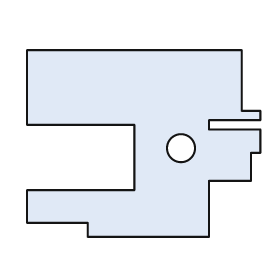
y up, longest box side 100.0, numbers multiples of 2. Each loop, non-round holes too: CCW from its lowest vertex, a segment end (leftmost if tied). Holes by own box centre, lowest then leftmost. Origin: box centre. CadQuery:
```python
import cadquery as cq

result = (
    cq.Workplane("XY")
    .moveTo(-24.0, -40.0)
    .lineTo(28.0, -40.0)
    .lineTo(28.0, -16.0)
    .lineTo(46.0, -16.0)
    .lineTo(46.0, -4.0)
    .lineTo(50.0, -4.0)
    .lineTo(50.0, 6.0)
    .lineTo(28.0, 6.0)
    .lineTo(28.0, 10.0)
    .lineTo(50.0, 10.0)
    .lineTo(50.0, 14.0)
    .lineTo(42.0, 14.0)
    .lineTo(42.0, 40.0)
    .lineTo(-50.0, 40.0)
    .lineTo(-50.0, 8.0)
    .lineTo(-4.0, 8.0)
    .lineTo(-4.0, -20.0)
    .lineTo(-50.0, -20.0)
    .lineTo(-50.0, -34.0)
    .lineTo(-24.0, -34.0)
    .close()
    .moveTo(16.0, -2.0)
    .circle(6.0)
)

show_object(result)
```